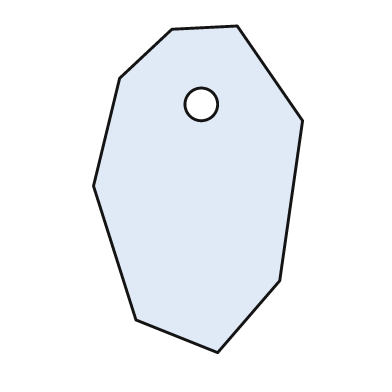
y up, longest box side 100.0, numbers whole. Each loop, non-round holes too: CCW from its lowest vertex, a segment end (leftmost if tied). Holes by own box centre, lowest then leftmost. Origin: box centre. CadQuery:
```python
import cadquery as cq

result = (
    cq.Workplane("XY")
    .moveTo(6.0, -50.0)
    .lineTo(25.0, -28.0)
    .lineTo(32.0, 21.0)
    .lineTo(12.0, 50.0)
    .lineTo(-8.0, 49.0)
    .lineTo(-24.0, 34.0)
    .lineTo(-32.0, 1.0)
    .lineTo(-19.0, -40.0)
    .close()
    .moveTo(1.0, 26.0)
    .circle(5.0)
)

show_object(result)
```